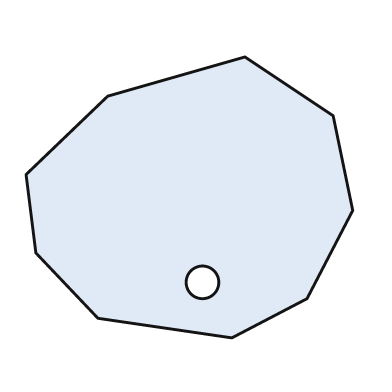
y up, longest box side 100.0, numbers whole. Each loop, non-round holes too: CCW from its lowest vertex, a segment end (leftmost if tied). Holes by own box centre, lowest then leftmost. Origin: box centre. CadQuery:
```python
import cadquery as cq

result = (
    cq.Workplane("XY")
    .moveTo(13.0, -43.0)
    .lineTo(36.0, -31.0)
    .lineTo(50.0, -4.0)
    .lineTo(44.0, 25.0)
    .lineTo(17.0, 43.0)
    .lineTo(-25.0, 31.0)
    .lineTo(-50.0, 7.0)
    .lineTo(-47.0, -17.0)
    .lineTo(-28.0, -37.0)
    .close()
    .moveTo(4.0, -26.0)
    .circle(5.0)
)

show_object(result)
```